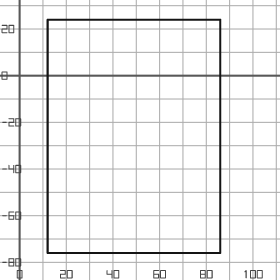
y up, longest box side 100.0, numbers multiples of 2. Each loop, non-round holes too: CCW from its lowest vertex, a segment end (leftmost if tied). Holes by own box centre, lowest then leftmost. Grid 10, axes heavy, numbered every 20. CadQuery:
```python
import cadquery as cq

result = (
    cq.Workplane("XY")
    .moveTo(12.0, -76.0)
    .lineTo(86.0, -76.0)
    .lineTo(86.0, 24.0)
    .lineTo(12.0, 24.0)
    .close()
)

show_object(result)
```